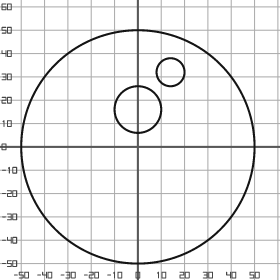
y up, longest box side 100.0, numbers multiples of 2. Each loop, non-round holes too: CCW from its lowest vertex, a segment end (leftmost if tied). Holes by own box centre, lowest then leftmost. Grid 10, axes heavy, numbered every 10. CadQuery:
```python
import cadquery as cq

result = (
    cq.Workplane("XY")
    .moveTo(0.0, 0.0)
    .circle(50.0)
    .moveTo(0.0, 16.0)
    .circle(10.0)
    .moveTo(14.0, 32.0)
    .circle(6.0)
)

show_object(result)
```